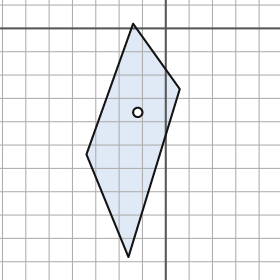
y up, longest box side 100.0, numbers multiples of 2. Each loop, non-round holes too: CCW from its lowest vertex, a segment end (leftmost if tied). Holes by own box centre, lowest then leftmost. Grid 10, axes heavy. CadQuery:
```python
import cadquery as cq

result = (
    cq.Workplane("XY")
    .moveTo(-16.0, -98.0)
    .lineTo(6.0, -26.0)
    .lineTo(-14.0, 2.0)
    .lineTo(-34.0, -54.0)
    .close()
    .moveTo(-12.0, -36.0)
    .circle(2.0)
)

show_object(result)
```